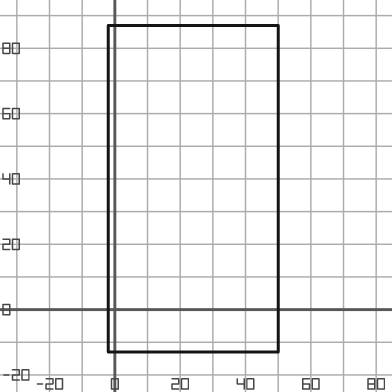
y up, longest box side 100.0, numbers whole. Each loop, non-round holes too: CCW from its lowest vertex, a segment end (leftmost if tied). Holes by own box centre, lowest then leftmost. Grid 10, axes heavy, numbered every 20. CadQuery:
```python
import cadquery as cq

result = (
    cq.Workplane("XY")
    .moveTo(-2.0, -13.0)
    .lineTo(50.0, -13.0)
    .lineTo(50.0, 87.0)
    .lineTo(-2.0, 87.0)
    .close()
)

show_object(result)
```